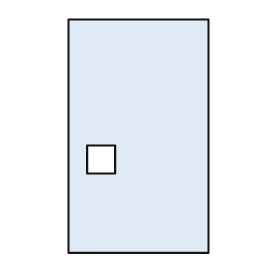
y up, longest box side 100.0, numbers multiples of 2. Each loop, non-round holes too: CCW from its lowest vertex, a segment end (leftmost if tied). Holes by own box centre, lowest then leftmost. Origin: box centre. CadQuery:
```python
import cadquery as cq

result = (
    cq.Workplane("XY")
    .moveTo(-30.0, -50.0)
    .lineTo(30.0, -50.0)
    .lineTo(30.0, 50.0)
    .lineTo(-30.0, 50.0)
    .close()
    .moveTo(-22.0, -16.0)
    .lineTo(-10.0, -16.0)
    .lineTo(-10.0, -4.0)
    .lineTo(-22.0, -4.0)
    .close()
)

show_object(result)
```